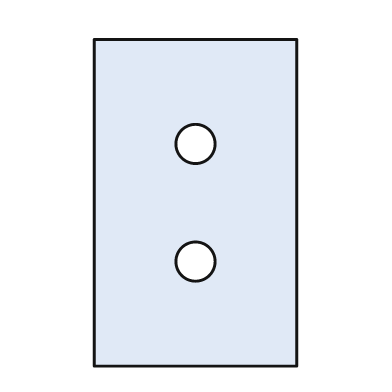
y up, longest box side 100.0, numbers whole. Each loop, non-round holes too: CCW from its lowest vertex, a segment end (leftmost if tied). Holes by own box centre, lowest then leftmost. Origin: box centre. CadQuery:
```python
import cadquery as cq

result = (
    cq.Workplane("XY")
    .moveTo(-31.0, -50.0)
    .lineTo(31.0, -50.0)
    .lineTo(31.0, 50.0)
    .lineTo(-31.0, 50.0)
    .close()
    .moveTo(0.0, -18.0)
    .circle(6.0)
    .moveTo(0.0, 18.0)
    .circle(6.0)
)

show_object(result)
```